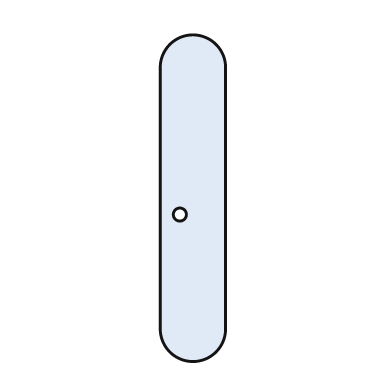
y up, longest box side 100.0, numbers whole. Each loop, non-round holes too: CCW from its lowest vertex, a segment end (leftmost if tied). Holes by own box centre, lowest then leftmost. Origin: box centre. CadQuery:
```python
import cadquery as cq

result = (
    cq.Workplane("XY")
    .moveTo(-10.0, -40.0)
    .threePointArc((0.0, -50.0), (10.0, -40.0))
    .lineTo(10.0, 40.0)
    .threePointArc((0.0, 50.0), (-10.0, 40.0))
    .close()
    .moveTo(-4.0, -5.0)
    .circle(2.0)
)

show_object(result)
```